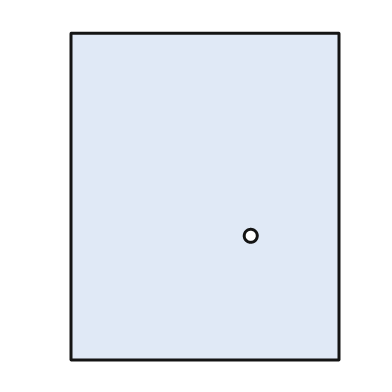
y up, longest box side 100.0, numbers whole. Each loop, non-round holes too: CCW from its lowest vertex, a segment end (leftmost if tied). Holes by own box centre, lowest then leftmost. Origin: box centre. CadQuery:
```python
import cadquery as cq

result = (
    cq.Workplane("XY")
    .moveTo(-41.0, -50.0)
    .lineTo(41.0, -50.0)
    .lineTo(41.0, 50.0)
    .lineTo(-41.0, 50.0)
    .close()
    .moveTo(14.0, -12.0)
    .circle(2.0)
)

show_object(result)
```